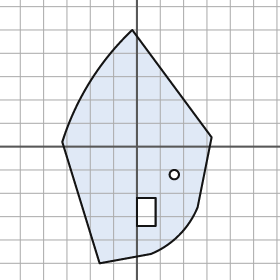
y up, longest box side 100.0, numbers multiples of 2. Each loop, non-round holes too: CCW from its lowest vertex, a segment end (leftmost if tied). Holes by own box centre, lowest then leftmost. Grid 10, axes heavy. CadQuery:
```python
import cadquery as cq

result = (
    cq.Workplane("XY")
    .moveTo(-16.0, -50.0)
    .lineTo(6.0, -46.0)
    .threePointArc((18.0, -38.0), (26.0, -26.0))
    .lineTo(32.0, 4.0)
    .lineTo(-2.0, 50.0)
    .threePointArc((-20.0, 28.0), (-32.0, 2.0))
    .close()
    .moveTo(0.0, -34.0)
    .lineTo(8.0, -34.0)
    .lineTo(8.0, -22.0)
    .lineTo(0.0, -22.0)
    .close()
    .moveTo(16.0, -12.0)
    .circle(2.0)
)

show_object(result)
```